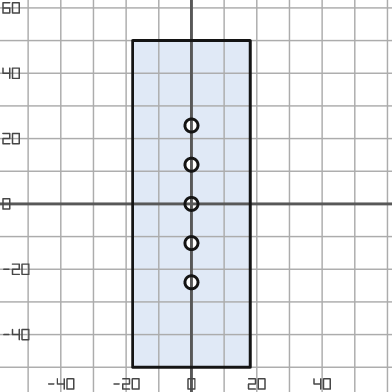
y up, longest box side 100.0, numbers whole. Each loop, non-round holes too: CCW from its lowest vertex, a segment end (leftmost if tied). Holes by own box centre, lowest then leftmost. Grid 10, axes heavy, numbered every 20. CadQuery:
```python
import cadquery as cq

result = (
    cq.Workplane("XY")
    .moveTo(-18.0, -50.0)
    .lineTo(18.0, -50.0)
    .lineTo(18.0, 50.0)
    .lineTo(-18.0, 50.0)
    .close()
    .moveTo(0.0, -24.0)
    .circle(2.0)
    .moveTo(0.0, -12.0)
    .circle(2.0)
    .moveTo(0.0, 0.0)
    .circle(2.0)
    .moveTo(0.0, 12.0)
    .circle(2.0)
    .moveTo(0.0, 24.0)
    .circle(2.0)
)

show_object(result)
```